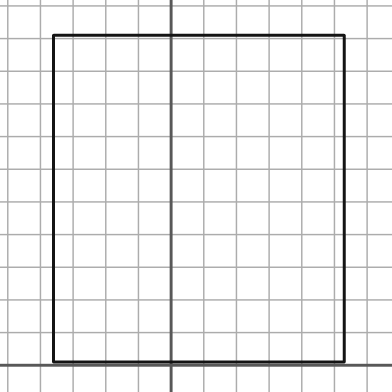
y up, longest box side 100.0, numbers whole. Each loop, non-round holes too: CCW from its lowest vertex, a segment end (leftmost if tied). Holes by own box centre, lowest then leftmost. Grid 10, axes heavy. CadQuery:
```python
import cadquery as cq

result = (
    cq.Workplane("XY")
    .moveTo(-36.0, 1.0)
    .lineTo(53.0, 1.0)
    .lineTo(53.0, 101.0)
    .lineTo(-36.0, 101.0)
    .close()
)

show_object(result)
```